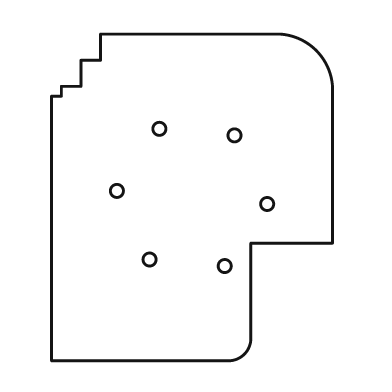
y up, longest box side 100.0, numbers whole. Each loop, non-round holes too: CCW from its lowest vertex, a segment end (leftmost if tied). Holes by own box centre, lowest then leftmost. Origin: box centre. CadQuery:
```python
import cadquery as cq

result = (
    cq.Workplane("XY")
    .moveTo(-43.0, -50.0)
    .lineTo(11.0, -50.0)
    .threePointArc((16.0, -48.0), (18.0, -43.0))
    .lineTo(18.0, -14.0)
    .lineTo(43.0, -14.0)
    .lineTo(43.0, 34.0)
    .threePointArc((38.0, 45.0), (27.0, 50.0))
    .lineTo(-28.0, 50.0)
    .lineTo(-28.0, 42.0)
    .lineTo(-34.0, 42.0)
    .lineTo(-34.0, 34.0)
    .lineTo(-40.0, 34.0)
    .lineTo(-40.0, 31.0)
    .lineTo(-43.0, 31.0)
    .close()
    .moveTo(10.0, -21.0)
    .circle(2.0)
    .moveTo(-13.0, -19.0)
    .circle(2.0)
    .moveTo(23.0, -2.0)
    .circle(2.0)
    .moveTo(-23.0, 2.0)
    .circle(2.0)
    .moveTo(13.0, 19.0)
    .circle(2.0)
    .moveTo(-10.0, 21.0)
    .circle(2.0)
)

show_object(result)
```